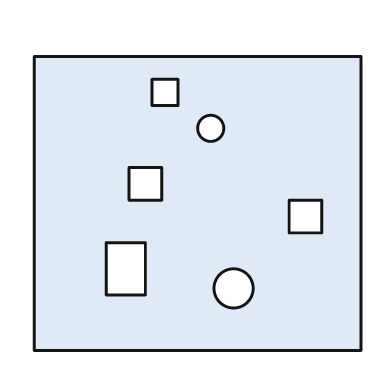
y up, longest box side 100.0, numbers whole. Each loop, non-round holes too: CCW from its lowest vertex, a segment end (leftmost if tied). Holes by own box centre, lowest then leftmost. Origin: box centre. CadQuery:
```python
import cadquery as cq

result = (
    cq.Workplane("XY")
    .moveTo(-50.0, -45.0)
    .lineTo(50.0, -45.0)
    .lineTo(50.0, 45.0)
    .lineTo(-50.0, 45.0)
    .close()
    .moveTo(11.0, -26.0)
    .circle(6.0)
    .moveTo(-28.0, -28.0)
    .lineTo(-16.0, -28.0)
    .lineTo(-16.0, -12.0)
    .lineTo(-28.0, -12.0)
    .close()
    .moveTo(28.0, -9.0)
    .lineTo(38.0, -9.0)
    .lineTo(38.0, 1.0)
    .lineTo(28.0, 1.0)
    .close()
    .moveTo(-21.0, 1.0)
    .lineTo(-11.0, 1.0)
    .lineTo(-11.0, 11.0)
    .lineTo(-21.0, 11.0)
    .close()
    .moveTo(4.0, 23.0)
    .circle(4.0)
    .moveTo(-14.0, 30.0)
    .lineTo(-6.0, 30.0)
    .lineTo(-6.0, 38.0)
    .lineTo(-14.0, 38.0)
    .close()
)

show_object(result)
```